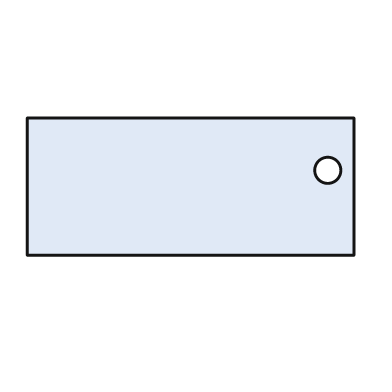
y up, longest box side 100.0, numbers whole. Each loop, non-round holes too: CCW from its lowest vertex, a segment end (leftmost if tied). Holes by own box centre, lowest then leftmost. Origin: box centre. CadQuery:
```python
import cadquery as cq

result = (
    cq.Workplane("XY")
    .moveTo(-50.0, -21.0)
    .lineTo(50.0, -21.0)
    .lineTo(50.0, 21.0)
    .lineTo(-50.0, 21.0)
    .close()
    .moveTo(42.0, 5.0)
    .circle(4.0)
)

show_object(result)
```